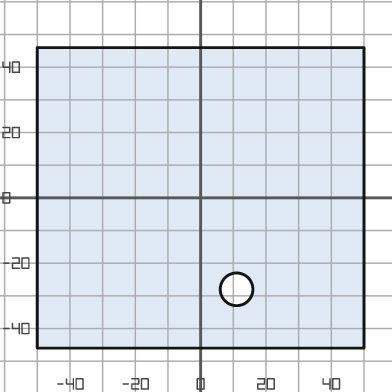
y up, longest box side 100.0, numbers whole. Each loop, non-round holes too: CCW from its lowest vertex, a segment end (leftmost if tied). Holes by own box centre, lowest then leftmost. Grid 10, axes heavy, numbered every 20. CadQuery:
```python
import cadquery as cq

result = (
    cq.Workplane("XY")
    .moveTo(-50.0, -46.0)
    .lineTo(50.0, -46.0)
    .lineTo(50.0, 46.0)
    .lineTo(-50.0, 46.0)
    .close()
    .moveTo(11.0, -28.0)
    .circle(5.0)
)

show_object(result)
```